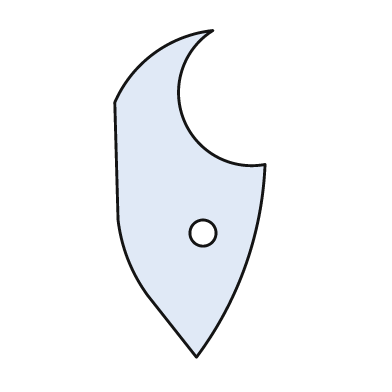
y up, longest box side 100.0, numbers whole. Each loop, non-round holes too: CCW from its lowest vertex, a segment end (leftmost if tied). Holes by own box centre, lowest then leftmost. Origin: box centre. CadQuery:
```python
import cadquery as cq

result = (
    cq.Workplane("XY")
    .moveTo(2.0, -50.0)
    .threePointArc((17.0, -22.0), (23.0, 9.0))
    .threePointArc((-2.0, 23.0), (7.0, 50.0))
    .threePointArc((-11.0, 43.0), (-23.0, 28.0))
    .lineTo(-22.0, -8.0)
    .threePointArc((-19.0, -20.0), (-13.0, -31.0))
    .close()
    .moveTo(4.0, -12.0)
    .circle(4.0)
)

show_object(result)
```